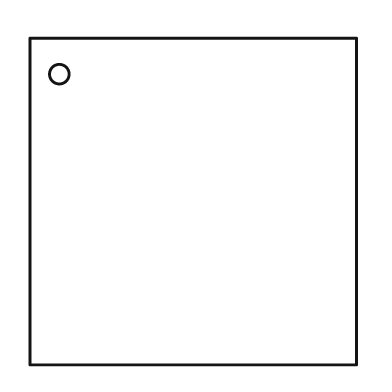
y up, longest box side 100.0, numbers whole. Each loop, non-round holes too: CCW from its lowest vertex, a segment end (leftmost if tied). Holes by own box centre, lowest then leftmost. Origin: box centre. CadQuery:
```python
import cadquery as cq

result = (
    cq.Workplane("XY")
    .moveTo(-50.0, -50.0)
    .lineTo(50.0, -50.0)
    .lineTo(50.0, 50.0)
    .lineTo(-50.0, 50.0)
    .close()
    .moveTo(-41.0, 39.0)
    .circle(3.0)
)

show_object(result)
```